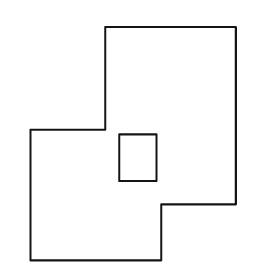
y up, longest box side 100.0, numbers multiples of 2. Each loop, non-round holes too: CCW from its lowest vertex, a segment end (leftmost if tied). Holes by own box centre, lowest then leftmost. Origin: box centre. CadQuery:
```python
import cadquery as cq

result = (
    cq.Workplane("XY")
    .moveTo(-44.0, -50.0)
    .lineTo(12.0, -50.0)
    .lineTo(12.0, -26.0)
    .lineTo(44.0, -26.0)
    .lineTo(44.0, 50.0)
    .lineTo(-12.0, 50.0)
    .lineTo(-12.0, 6.0)
    .lineTo(-44.0, 6.0)
    .close()
    .moveTo(-6.0, -16.0)
    .lineTo(10.0, -16.0)
    .lineTo(10.0, 4.0)
    .lineTo(-6.0, 4.0)
    .close()
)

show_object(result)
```